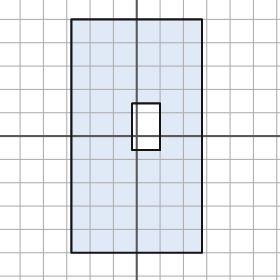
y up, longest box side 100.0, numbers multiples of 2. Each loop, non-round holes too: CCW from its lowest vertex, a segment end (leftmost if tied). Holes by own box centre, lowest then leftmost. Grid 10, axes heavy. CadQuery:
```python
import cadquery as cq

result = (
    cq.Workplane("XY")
    .moveTo(-28.0, -50.0)
    .lineTo(28.0, -50.0)
    .lineTo(28.0, 50.0)
    .lineTo(-28.0, 50.0)
    .close()
    .moveTo(-2.0, -6.0)
    .lineTo(10.0, -6.0)
    .lineTo(10.0, 14.0)
    .lineTo(-2.0, 14.0)
    .close()
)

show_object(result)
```